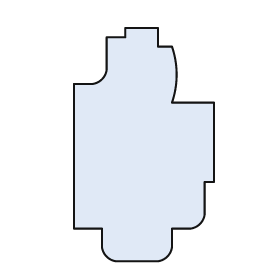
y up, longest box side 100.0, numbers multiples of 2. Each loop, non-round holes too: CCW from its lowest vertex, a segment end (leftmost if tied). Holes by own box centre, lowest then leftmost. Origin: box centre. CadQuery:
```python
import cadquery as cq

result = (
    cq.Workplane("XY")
    .moveTo(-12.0, -50.0)
    .lineTo(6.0, -50.0)
    .threePointArc((10.0, -48.0), (12.0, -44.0))
    .lineTo(12.0, -36.0)
    .lineTo(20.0, -36.0)
    .threePointArc((24.0, -34.0), (26.0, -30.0))
    .lineTo(26.0, -16.0)
    .lineTo(30.0, -16.0)
    .lineTo(30.0, 18.0)
    .lineTo(12.0, 18.0)
    .threePointArc((14.0, 30.0), (12.0, 42.0))
    .lineTo(6.0, 42.0)
    .lineTo(6.0, 50.0)
    .lineTo(-8.0, 50.0)
    .lineTo(-8.0, 46.0)
    .lineTo(-16.0, 46.0)
    .lineTo(-16.0, 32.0)
    .threePointArc((-18.0, 28.0), (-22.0, 26.0))
    .lineTo(-30.0, 26.0)
    .lineTo(-30.0, -36.0)
    .lineTo(-18.0, -36.0)
    .lineTo(-18.0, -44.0)
    .threePointArc((-16.0, -48.0), (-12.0, -50.0))
    .close()
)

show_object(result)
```